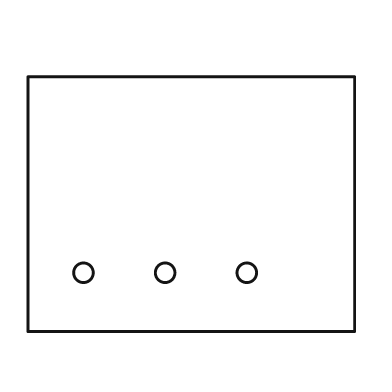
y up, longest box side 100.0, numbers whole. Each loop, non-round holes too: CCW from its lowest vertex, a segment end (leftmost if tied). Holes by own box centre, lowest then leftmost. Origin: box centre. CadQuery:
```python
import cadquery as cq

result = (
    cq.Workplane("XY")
    .moveTo(-50.0, -39.0)
    .lineTo(50.0, -39.0)
    .lineTo(50.0, 39.0)
    .lineTo(-50.0, 39.0)
    .close()
    .moveTo(-33.0, -21.0)
    .circle(3.0)
    .moveTo(-8.0, -21.0)
    .circle(3.0)
    .moveTo(17.0, -21.0)
    .circle(3.0)
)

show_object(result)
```